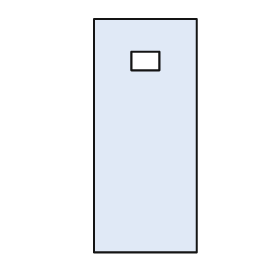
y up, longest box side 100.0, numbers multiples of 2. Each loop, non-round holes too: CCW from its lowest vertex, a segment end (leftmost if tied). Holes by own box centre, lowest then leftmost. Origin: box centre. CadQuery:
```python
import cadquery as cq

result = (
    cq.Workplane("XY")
    .moveTo(-22.0, -50.0)
    .lineTo(22.0, -50.0)
    .lineTo(22.0, 50.0)
    .lineTo(-22.0, 50.0)
    .close()
    .moveTo(-6.0, 28.0)
    .lineTo(6.0, 28.0)
    .lineTo(6.0, 36.0)
    .lineTo(-6.0, 36.0)
    .close()
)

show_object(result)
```